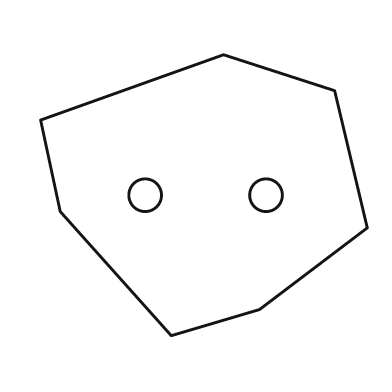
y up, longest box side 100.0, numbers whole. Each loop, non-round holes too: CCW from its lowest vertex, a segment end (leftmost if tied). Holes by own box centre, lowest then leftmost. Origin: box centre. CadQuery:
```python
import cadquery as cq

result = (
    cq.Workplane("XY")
    .moveTo(-10.0, -43.0)
    .lineTo(17.0, -35.0)
    .lineTo(50.0, -10.0)
    .lineTo(40.0, 32.0)
    .lineTo(6.0, 43.0)
    .lineTo(-50.0, 23.0)
    .lineTo(-44.0, -5.0)
    .close()
    .moveTo(-18.0, 0.0)
    .circle(5.0)
    .moveTo(19.0, 0.0)
    .circle(5.0)
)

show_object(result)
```